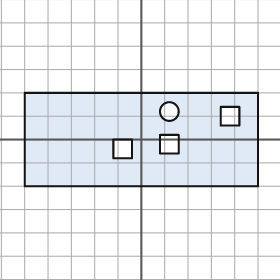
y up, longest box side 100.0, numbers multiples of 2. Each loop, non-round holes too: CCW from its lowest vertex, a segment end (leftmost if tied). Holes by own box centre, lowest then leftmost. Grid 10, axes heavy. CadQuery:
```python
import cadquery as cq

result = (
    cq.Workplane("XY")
    .moveTo(-50.0, -20.0)
    .lineTo(50.0, -20.0)
    .lineTo(50.0, 20.0)
    .lineTo(-50.0, 20.0)
    .close()
    .moveTo(-12.0, -8.0)
    .lineTo(-4.0, -8.0)
    .lineTo(-4.0, 0.0)
    .lineTo(-12.0, 0.0)
    .close()
    .moveTo(8.0, -6.0)
    .lineTo(16.0, -6.0)
    .lineTo(16.0, 2.0)
    .lineTo(8.0, 2.0)
    .close()
    .moveTo(34.0, 6.0)
    .lineTo(42.0, 6.0)
    .lineTo(42.0, 14.0)
    .lineTo(34.0, 14.0)
    .close()
    .moveTo(12.0, 12.0)
    .circle(4.0)
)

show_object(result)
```